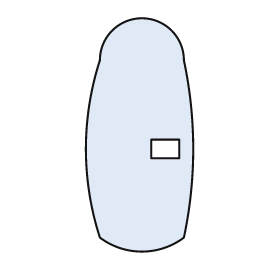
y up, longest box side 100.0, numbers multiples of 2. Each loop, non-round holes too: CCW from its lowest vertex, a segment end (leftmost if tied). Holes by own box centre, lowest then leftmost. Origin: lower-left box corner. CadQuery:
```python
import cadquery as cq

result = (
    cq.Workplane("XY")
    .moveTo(6.0, 6.0)
    .threePointArc((24.0, 0.0), (42.0, 6.0))
    .threePointArc((46.0, 44.0), (42.0, 82.0))
    .threePointArc((24.0, 100.0), (6.0, 82.0))
    .threePointArc((0.0, 44.0), (6.0, 6.0))
    .close()
    .moveTo(28.0, 40.0)
    .lineTo(40.0, 40.0)
    .lineTo(40.0, 48.0)
    .lineTo(28.0, 48.0)
    .close()
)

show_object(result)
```